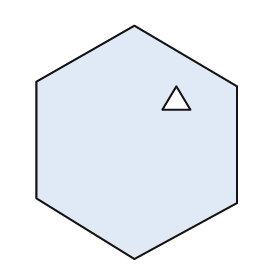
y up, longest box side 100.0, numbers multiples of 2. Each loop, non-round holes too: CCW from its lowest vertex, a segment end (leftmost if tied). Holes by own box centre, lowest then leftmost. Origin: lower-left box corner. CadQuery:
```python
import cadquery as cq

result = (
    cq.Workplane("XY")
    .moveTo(42.0, 0.0)
    .lineTo(86.0, 24.0)
    .lineTo(86.0, 74.0)
    .lineTo(42.0, 100.0)
    .lineTo(0.0, 76.0)
    .lineTo(0.0, 26.0)
    .close()
    .moveTo(54.0, 64.0)
    .lineTo(66.0, 64.0)
    .lineTo(60.0, 74.0)
    .close()
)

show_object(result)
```